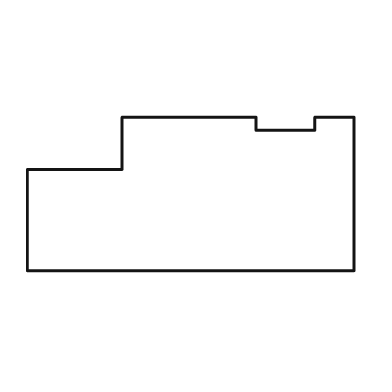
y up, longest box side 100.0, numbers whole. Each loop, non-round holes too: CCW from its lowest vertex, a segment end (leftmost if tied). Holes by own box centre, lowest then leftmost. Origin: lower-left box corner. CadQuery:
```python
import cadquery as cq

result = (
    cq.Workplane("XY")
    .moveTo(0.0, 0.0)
    .lineTo(100.0, 0.0)
    .lineTo(100.0, 47.0)
    .lineTo(88.0, 47.0)
    .lineTo(88.0, 43.0)
    .lineTo(70.0, 43.0)
    .lineTo(70.0, 47.0)
    .lineTo(29.0, 47.0)
    .lineTo(29.0, 31.0)
    .lineTo(0.0, 31.0)
    .close()
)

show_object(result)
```